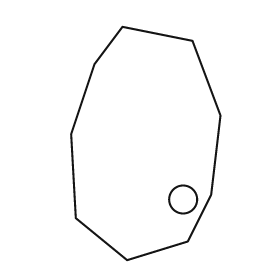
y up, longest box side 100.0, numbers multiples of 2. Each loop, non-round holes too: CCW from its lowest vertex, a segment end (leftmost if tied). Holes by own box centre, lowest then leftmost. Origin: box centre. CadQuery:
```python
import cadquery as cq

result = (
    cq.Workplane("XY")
    .moveTo(-8.0, -50.0)
    .lineTo(18.0, -42.0)
    .lineTo(28.0, -22.0)
    .lineTo(32.0, 12.0)
    .lineTo(20.0, 44.0)
    .lineTo(-10.0, 50.0)
    .lineTo(-22.0, 34.0)
    .lineTo(-32.0, 4.0)
    .lineTo(-30.0, -32.0)
    .close()
    .moveTo(16.0, -24.0)
    .circle(6.0)
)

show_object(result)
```